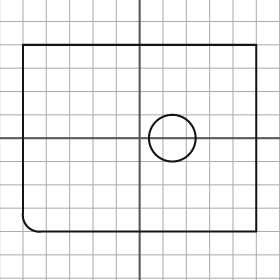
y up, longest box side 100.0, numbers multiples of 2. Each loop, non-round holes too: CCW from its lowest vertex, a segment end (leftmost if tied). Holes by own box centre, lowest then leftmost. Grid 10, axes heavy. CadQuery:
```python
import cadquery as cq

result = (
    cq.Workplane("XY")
    .moveTo(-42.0, -40.0)
    .lineTo(50.0, -40.0)
    .lineTo(50.0, 40.0)
    .lineTo(-50.0, 40.0)
    .lineTo(-50.0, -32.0)
    .threePointArc((-48.0, -38.0), (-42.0, -40.0))
    .close()
    .moveTo(14.0, 0.0)
    .circle(10.0)
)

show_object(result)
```